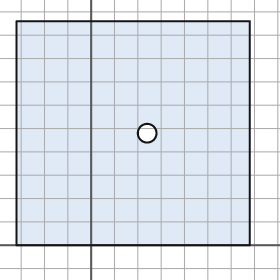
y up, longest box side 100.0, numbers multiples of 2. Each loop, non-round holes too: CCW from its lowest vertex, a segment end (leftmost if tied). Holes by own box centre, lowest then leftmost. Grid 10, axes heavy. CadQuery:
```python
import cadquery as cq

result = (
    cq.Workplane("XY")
    .moveTo(-32.0, 0.0)
    .lineTo(68.0, 0.0)
    .lineTo(68.0, 96.0)
    .lineTo(-32.0, 96.0)
    .close()
    .moveTo(24.0, 48.0)
    .circle(4.0)
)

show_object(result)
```